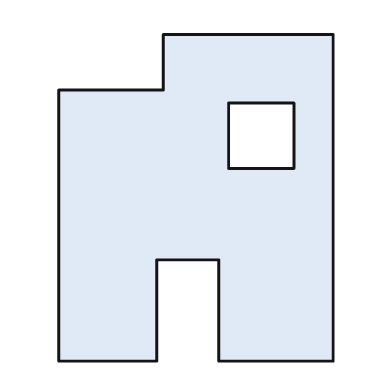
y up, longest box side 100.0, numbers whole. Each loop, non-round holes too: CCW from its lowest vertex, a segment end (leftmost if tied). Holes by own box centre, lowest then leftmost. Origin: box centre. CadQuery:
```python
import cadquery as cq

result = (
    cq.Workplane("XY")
    .moveTo(-42.0, -50.0)
    .lineTo(-12.0, -50.0)
    .lineTo(-12.0, -19.0)
    .lineTo(7.0, -19.0)
    .lineTo(7.0, -50.0)
    .lineTo(42.0, -50.0)
    .lineTo(42.0, 50.0)
    .lineTo(-10.0, 50.0)
    .lineTo(-10.0, 33.0)
    .lineTo(-42.0, 33.0)
    .close()
    .moveTo(10.0, 9.0)
    .lineTo(30.0, 9.0)
    .lineTo(30.0, 29.0)
    .lineTo(10.0, 29.0)
    .close()
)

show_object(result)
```